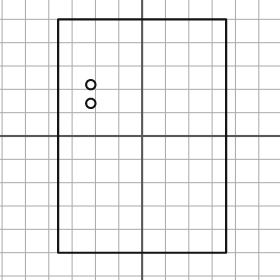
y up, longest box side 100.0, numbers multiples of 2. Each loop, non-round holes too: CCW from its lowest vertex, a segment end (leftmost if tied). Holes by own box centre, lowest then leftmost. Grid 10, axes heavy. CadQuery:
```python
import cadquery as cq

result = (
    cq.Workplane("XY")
    .moveTo(-36.0, -50.0)
    .lineTo(36.0, -50.0)
    .lineTo(36.0, 50.0)
    .lineTo(-36.0, 50.0)
    .close()
    .moveTo(-22.0, 14.0)
    .circle(2.0)
    .moveTo(-22.0, 22.0)
    .circle(2.0)
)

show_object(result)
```